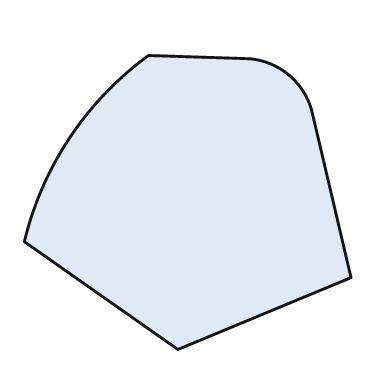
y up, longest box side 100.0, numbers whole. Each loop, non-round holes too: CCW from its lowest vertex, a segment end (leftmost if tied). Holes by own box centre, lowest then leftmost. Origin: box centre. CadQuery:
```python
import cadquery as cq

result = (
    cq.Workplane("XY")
    .moveTo(-3.0, -45.0)
    .lineTo(50.0, -23.0)
    .lineTo(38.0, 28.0)
    .threePointArc((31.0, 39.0), (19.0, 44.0))
    .lineTo(-12.0, 45.0)
    .threePointArc((-36.0, 20.0), (-50.0, -12.0))
    .close()
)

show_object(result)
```